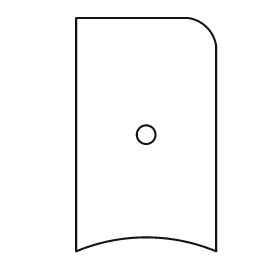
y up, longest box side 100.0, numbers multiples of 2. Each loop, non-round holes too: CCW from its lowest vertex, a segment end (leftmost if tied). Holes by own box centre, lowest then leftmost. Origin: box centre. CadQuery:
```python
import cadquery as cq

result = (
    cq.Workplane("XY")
    .moveTo(-30.0, -50.0)
    .threePointArc((0.0, -44.0), (30.0, -50.0))
    .lineTo(30.0, 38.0)
    .threePointArc((26.0, 46.0), (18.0, 50.0))
    .lineTo(-30.0, 50.0)
    .close()
    .moveTo(0.0, 0.0)
    .circle(4.0)
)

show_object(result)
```